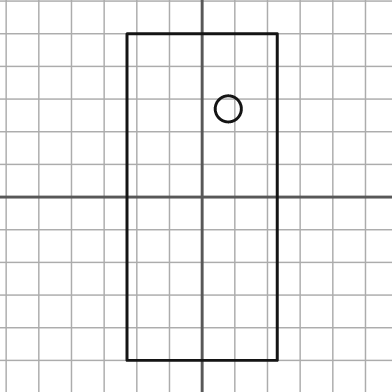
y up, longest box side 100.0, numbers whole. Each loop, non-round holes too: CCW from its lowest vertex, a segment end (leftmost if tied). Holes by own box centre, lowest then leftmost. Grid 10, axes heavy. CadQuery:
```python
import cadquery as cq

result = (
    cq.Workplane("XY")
    .moveTo(-23.0, -50.0)
    .lineTo(23.0, -50.0)
    .lineTo(23.0, 50.0)
    .lineTo(-23.0, 50.0)
    .close()
    .moveTo(8.0, 27.0)
    .circle(4.0)
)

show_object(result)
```